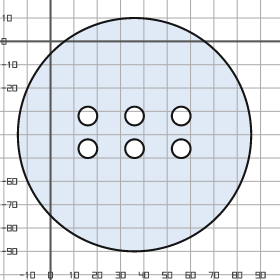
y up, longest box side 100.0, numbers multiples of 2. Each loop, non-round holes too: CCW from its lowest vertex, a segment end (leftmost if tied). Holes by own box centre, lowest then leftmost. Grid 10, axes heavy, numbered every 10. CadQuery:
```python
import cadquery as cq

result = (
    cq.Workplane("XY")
    .moveTo(36.0, -40.0)
    .circle(50.0)
    .moveTo(16.0, -46.0)
    .circle(4.0)
    .moveTo(36.0, -46.0)
    .circle(4.0)
    .moveTo(56.0, -46.0)
    .circle(4.0)
    .moveTo(16.0, -32.0)
    .circle(4.0)
    .moveTo(36.0, -32.0)
    .circle(4.0)
    .moveTo(56.0, -32.0)
    .circle(4.0)
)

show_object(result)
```